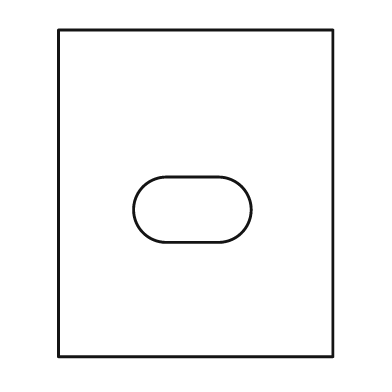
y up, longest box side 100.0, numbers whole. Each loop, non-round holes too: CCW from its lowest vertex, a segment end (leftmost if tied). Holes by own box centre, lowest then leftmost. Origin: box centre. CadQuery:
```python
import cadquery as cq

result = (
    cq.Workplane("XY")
    .moveTo(-42.0, -50.0)
    .lineTo(42.0, -50.0)
    .lineTo(42.0, 50.0)
    .lineTo(-42.0, 50.0)
    .close()
    .moveTo(-9.0, -15.0)
    .lineTo(7.0, -15.0)
    .threePointArc((17.0, -5.0), (7.0, 5.0))
    .lineTo(-9.0, 5.0)
    .threePointArc((-19.0, -5.0), (-9.0, -15.0))
    .close()
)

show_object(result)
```